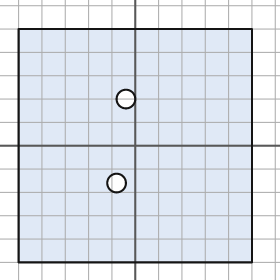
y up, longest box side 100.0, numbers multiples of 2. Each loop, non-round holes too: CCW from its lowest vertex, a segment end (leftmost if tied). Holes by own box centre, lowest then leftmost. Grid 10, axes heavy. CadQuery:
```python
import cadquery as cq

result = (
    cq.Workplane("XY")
    .moveTo(-50.0, -50.0)
    .lineTo(50.0, -50.0)
    .lineTo(50.0, 50.0)
    .lineTo(-50.0, 50.0)
    .close()
    .moveTo(-8.0, -16.0)
    .circle(4.0)
    .moveTo(-4.0, 20.0)
    .circle(4.0)
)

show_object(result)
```